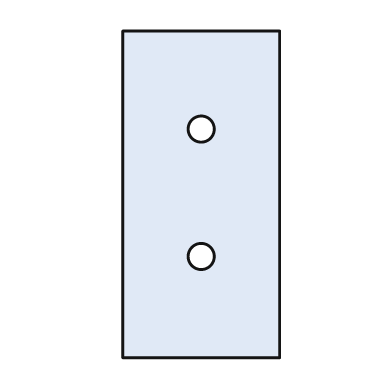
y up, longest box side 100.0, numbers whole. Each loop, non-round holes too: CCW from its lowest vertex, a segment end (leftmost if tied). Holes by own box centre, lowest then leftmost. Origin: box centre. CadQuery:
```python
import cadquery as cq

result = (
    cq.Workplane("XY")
    .moveTo(-24.0, -50.0)
    .lineTo(24.0, -50.0)
    .lineTo(24.0, 50.0)
    .lineTo(-24.0, 50.0)
    .close()
    .moveTo(0.0, -19.0)
    .circle(4.0)
    .moveTo(0.0, 20.0)
    .circle(4.0)
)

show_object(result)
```